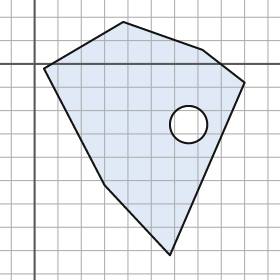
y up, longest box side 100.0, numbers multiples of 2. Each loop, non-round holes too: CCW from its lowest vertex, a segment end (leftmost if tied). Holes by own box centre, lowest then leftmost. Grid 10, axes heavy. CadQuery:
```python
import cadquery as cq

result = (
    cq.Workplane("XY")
    .moveTo(58.0, -82.0)
    .lineTo(90.0, -8.0)
    .lineTo(72.0, 6.0)
    .lineTo(38.0, 18.0)
    .lineTo(4.0, -2.0)
    .lineTo(30.0, -52.0)
    .close()
    .moveTo(66.0, -26.0)
    .circle(8.0)
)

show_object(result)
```